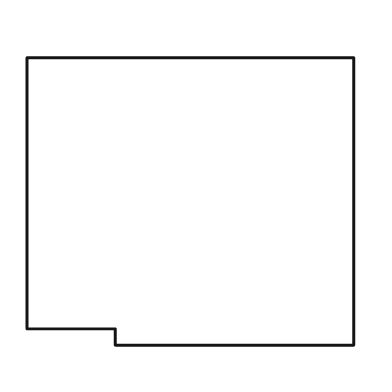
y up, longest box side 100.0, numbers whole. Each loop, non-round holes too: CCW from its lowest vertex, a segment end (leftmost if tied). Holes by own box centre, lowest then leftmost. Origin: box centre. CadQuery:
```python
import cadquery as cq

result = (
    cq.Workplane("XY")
    .moveTo(-23.0, -44.0)
    .lineTo(50.0, -44.0)
    .lineTo(50.0, 44.0)
    .lineTo(-50.0, 44.0)
    .lineTo(-50.0, -39.0)
    .lineTo(-23.0, -39.0)
    .close()
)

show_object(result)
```